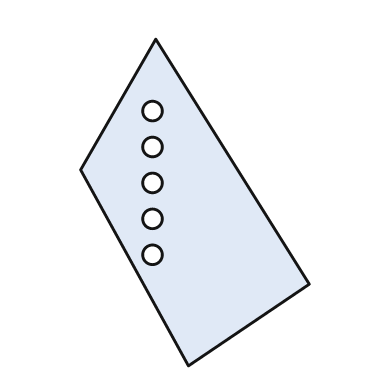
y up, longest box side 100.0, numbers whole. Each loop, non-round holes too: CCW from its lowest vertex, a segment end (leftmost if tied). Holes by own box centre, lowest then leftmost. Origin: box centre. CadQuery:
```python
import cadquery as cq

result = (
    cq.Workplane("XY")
    .moveTo(-2.0, -50.0)
    .lineTo(35.0, -25.0)
    .lineTo(-12.0, 50.0)
    .lineTo(-35.0, 10.0)
    .close()
    .moveTo(-13.0, -16.0)
    .circle(3.0)
    .moveTo(-13.0, -5.0)
    .circle(3.0)
    .moveTo(-13.0, 6.0)
    .circle(3.0)
    .moveTo(-13.0, 17.0)
    .circle(3.0)
    .moveTo(-13.0, 28.0)
    .circle(3.0)
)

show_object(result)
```